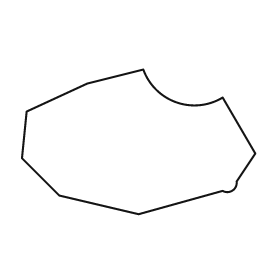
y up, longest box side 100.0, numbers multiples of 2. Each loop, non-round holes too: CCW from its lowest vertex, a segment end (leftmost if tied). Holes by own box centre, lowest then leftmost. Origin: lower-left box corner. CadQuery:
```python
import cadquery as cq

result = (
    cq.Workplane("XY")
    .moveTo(50.0, 0.0)
    .lineTo(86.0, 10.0)
    .threePointArc((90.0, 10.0), (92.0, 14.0))
    .lineTo(100.0, 26.0)
    .lineTo(86.0, 50.0)
    .threePointArc((66.0, 48.0), (52.0, 62.0))
    .lineTo(28.0, 56.0)
    .lineTo(2.0, 44.0)
    .lineTo(0.0, 24.0)
    .lineTo(16.0, 8.0)
    .close()
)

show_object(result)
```